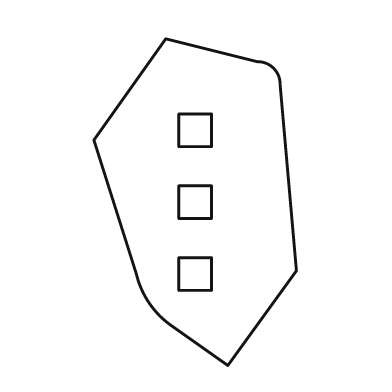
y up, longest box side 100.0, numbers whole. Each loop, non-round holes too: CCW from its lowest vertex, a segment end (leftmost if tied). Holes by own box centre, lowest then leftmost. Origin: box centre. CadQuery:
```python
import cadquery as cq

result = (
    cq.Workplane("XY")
    .moveTo(10.0, -50.0)
    .lineTo(31.0, -21.0)
    .lineTo(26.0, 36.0)
    .threePointArc((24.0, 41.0), (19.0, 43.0))
    .lineTo(-9.0, 50.0)
    .lineTo(-31.0, 19.0)
    .lineTo(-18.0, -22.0)
    .threePointArc((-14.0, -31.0), (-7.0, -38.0))
    .close()
    .moveTo(-5.0, -27.0)
    .lineTo(5.0, -27.0)
    .lineTo(5.0, -17.0)
    .lineTo(-5.0, -17.0)
    .close()
    .moveTo(-5.0, -5.0)
    .lineTo(5.0, -5.0)
    .lineTo(5.0, 5.0)
    .lineTo(-5.0, 5.0)
    .close()
    .moveTo(-5.0, 17.0)
    .lineTo(5.0, 17.0)
    .lineTo(5.0, 27.0)
    .lineTo(-5.0, 27.0)
    .close()
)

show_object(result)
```